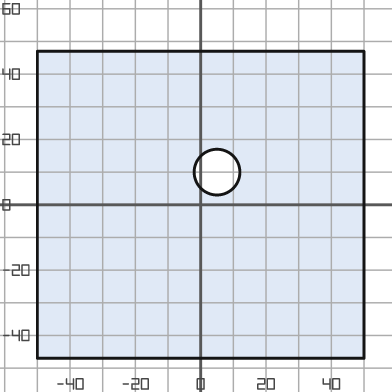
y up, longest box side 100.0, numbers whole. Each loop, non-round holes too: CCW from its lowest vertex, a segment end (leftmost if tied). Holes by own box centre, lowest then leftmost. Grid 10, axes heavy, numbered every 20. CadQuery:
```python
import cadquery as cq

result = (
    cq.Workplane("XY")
    .moveTo(-50.0, -47.0)
    .lineTo(50.0, -47.0)
    .lineTo(50.0, 47.0)
    .lineTo(-50.0, 47.0)
    .close()
    .moveTo(5.0, 10.0)
    .circle(7.0)
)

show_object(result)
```